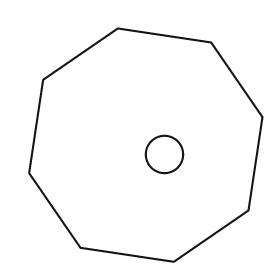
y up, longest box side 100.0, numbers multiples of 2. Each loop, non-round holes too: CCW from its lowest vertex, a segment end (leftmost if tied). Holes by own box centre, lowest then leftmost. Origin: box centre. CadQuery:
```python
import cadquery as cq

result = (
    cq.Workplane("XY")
    .moveTo(12.0, -50.0)
    .lineTo(44.0, -28.0)
    .lineTo(50.0, 12.0)
    .lineTo(28.0, 44.0)
    .lineTo(-12.0, 50.0)
    .lineTo(-44.0, 28.0)
    .lineTo(-50.0, -12.0)
    .lineTo(-28.0, -44.0)
    .close()
    .moveTo(8.0, -4.0)
    .circle(8.0)
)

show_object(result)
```